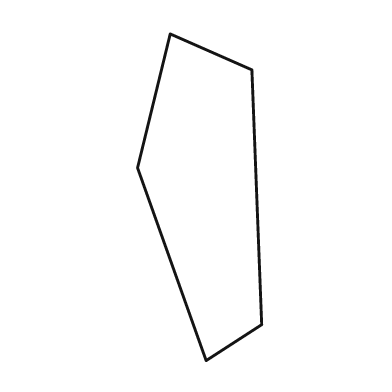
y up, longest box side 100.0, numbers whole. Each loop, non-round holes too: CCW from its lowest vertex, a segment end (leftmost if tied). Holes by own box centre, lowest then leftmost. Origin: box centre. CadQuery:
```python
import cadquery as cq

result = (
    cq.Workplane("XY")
    .moveTo(2.0, -50.0)
    .lineTo(19.0, -39.0)
    .lineTo(16.0, 39.0)
    .lineTo(-9.0, 50.0)
    .lineTo(-19.0, 9.0)
    .close()
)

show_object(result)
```